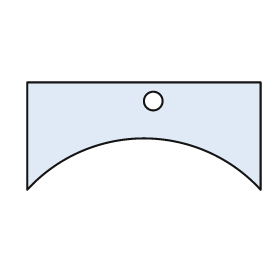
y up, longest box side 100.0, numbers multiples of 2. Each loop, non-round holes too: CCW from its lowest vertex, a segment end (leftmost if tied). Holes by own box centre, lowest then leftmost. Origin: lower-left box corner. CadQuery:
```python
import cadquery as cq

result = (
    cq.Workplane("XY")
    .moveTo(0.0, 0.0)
    .threePointArc((50.0, 22.0), (100.0, 0.0))
    .lineTo(100.0, 46.0)
    .lineTo(0.0, 46.0)
    .close()
    .moveTo(54.0, 38.0)
    .circle(4.0)
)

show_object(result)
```